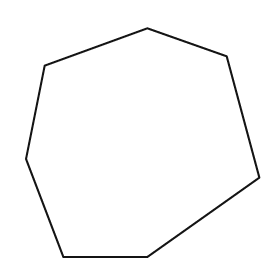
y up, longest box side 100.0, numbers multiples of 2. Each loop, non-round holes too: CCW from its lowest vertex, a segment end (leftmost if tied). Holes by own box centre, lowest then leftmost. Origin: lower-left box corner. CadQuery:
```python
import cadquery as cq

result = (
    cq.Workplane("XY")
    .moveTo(16.0, 0.0)
    .lineTo(52.0, 0.0)
    .lineTo(100.0, 34.0)
    .lineTo(86.0, 86.0)
    .lineTo(52.0, 98.0)
    .lineTo(8.0, 82.0)
    .lineTo(0.0, 42.0)
    .close()
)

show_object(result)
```